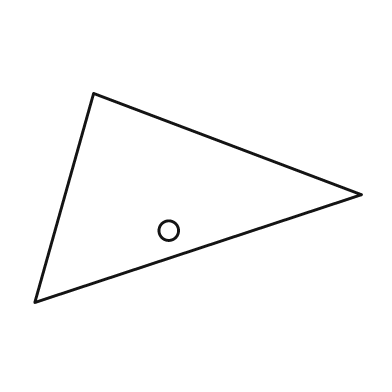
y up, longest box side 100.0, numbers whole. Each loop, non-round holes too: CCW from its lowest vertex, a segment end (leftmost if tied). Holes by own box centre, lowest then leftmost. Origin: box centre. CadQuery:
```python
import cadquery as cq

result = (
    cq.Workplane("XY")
    .moveTo(-50.0, -32.0)
    .lineTo(50.0, 1.0)
    .lineTo(-32.0, 32.0)
    .close()
    .moveTo(-9.0, -10.0)
    .circle(3.0)
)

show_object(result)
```